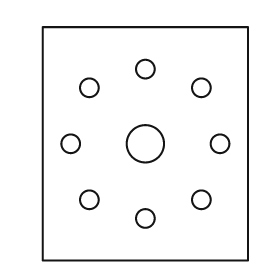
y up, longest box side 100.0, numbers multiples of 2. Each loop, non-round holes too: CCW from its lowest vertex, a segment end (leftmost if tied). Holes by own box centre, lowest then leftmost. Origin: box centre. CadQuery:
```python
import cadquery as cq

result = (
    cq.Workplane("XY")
    .moveTo(-44.0, -50.0)
    .lineTo(44.0, -50.0)
    .lineTo(44.0, 50.0)
    .lineTo(-44.0, 50.0)
    .close()
    .moveTo(0.0, -32.0)
    .circle(4.0)
    .moveTo(-24.0, -24.0)
    .circle(4.0)
    .moveTo(24.0, -24.0)
    .circle(4.0)
    .moveTo(-32.0, 0.0)
    .circle(4.0)
    .moveTo(0.0, 0.0)
    .circle(8.0)
    .moveTo(32.0, 0.0)
    .circle(4.0)
    .moveTo(-24.0, 24.0)
    .circle(4.0)
    .moveTo(24.0, 24.0)
    .circle(4.0)
    .moveTo(0.0, 32.0)
    .circle(4.0)
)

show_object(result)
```